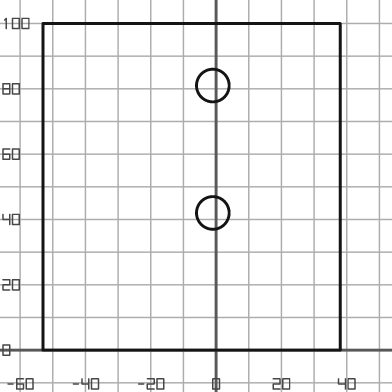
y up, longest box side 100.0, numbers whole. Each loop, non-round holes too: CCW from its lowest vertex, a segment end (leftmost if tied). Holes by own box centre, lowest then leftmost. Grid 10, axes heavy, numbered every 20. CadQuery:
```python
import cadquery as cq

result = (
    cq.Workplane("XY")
    .moveTo(-53.0, 0.0)
    .lineTo(38.0, 0.0)
    .lineTo(38.0, 100.0)
    .lineTo(-53.0, 100.0)
    .close()
    .moveTo(-1.0, 42.0)
    .circle(5.0)
    .moveTo(-1.0, 81.0)
    .circle(5.0)
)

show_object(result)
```